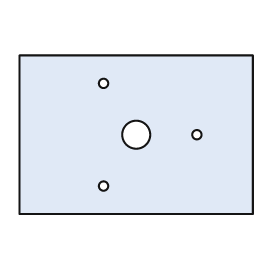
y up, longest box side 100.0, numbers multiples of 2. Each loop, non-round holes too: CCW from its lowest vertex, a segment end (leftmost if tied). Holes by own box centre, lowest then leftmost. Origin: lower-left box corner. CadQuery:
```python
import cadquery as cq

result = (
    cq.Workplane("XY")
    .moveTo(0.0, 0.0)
    .lineTo(100.0, 0.0)
    .lineTo(100.0, 68.0)
    .lineTo(0.0, 68.0)
    .close()
    .moveTo(36.0, 12.0)
    .circle(2.0)
    .moveTo(50.0, 34.0)
    .circle(6.0)
    .moveTo(76.0, 34.0)
    .circle(2.0)
    .moveTo(36.0, 56.0)
    .circle(2.0)
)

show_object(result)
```